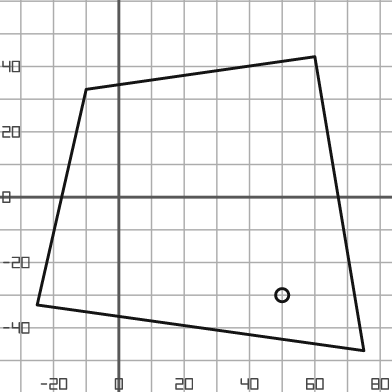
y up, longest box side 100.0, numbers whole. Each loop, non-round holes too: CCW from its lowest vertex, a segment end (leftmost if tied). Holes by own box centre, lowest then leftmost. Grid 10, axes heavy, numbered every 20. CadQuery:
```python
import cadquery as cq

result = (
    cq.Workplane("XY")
    .moveTo(75.0, -47.0)
    .lineTo(60.0, 43.0)
    .lineTo(-10.0, 33.0)
    .lineTo(-25.0, -33.0)
    .close()
    .moveTo(50.0, -30.0)
    .circle(2.0)
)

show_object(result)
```